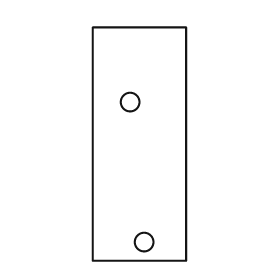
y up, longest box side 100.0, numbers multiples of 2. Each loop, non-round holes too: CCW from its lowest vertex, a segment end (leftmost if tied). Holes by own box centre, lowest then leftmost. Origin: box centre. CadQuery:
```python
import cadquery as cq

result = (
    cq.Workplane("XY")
    .moveTo(-20.0, -50.0)
    .lineTo(20.0, -50.0)
    .lineTo(20.0, 50.0)
    .lineTo(-20.0, 50.0)
    .close()
    .moveTo(2.0, -42.0)
    .circle(4.0)
    .moveTo(-4.0, 18.0)
    .circle(4.0)
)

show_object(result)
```